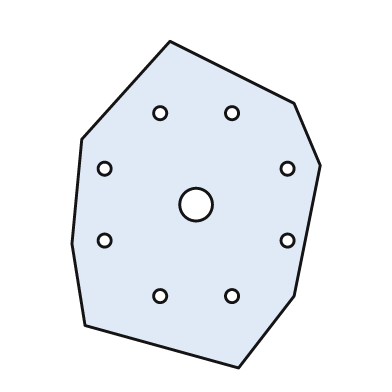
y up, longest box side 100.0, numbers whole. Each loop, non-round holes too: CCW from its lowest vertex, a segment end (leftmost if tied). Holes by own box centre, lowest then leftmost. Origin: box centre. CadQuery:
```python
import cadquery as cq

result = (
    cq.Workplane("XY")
    .moveTo(13.0, -50.0)
    .lineTo(30.0, -28.0)
    .lineTo(38.0, 12.0)
    .lineTo(30.0, 31.0)
    .lineTo(-8.0, 50.0)
    .lineTo(-35.0, 20.0)
    .lineTo(-38.0, -12.0)
    .lineTo(-34.0, -37.0)
    .close()
    .moveTo(-11.0, -28.0)
    .circle(2.0)
    .moveTo(11.0, -28.0)
    .circle(2.0)
    .moveTo(-28.0, -11.0)
    .circle(2.0)
    .moveTo(28.0, -11.0)
    .circle(2.0)
    .moveTo(0.0, 0.0)
    .circle(5.0)
    .moveTo(-28.0, 11.0)
    .circle(2.0)
    .moveTo(28.0, 11.0)
    .circle(2.0)
    .moveTo(-11.0, 28.0)
    .circle(2.0)
    .moveTo(11.0, 28.0)
    .circle(2.0)
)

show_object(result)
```